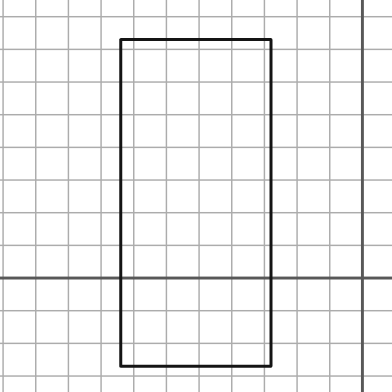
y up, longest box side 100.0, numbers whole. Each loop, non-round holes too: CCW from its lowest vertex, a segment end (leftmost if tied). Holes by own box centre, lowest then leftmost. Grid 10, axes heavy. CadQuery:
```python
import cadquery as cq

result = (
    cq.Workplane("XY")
    .moveTo(-74.0, -27.0)
    .lineTo(-28.0, -27.0)
    .lineTo(-28.0, 73.0)
    .lineTo(-74.0, 73.0)
    .close()
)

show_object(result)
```